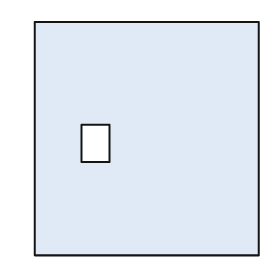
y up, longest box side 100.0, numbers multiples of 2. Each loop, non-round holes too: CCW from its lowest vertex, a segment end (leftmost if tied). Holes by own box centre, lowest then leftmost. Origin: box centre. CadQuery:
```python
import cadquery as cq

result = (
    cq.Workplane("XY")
    .moveTo(-48.0, -50.0)
    .lineTo(48.0, -50.0)
    .lineTo(48.0, 50.0)
    .lineTo(-48.0, 50.0)
    .close()
    .moveTo(-28.0, -10.0)
    .lineTo(-16.0, -10.0)
    .lineTo(-16.0, 6.0)
    .lineTo(-28.0, 6.0)
    .close()
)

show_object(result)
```